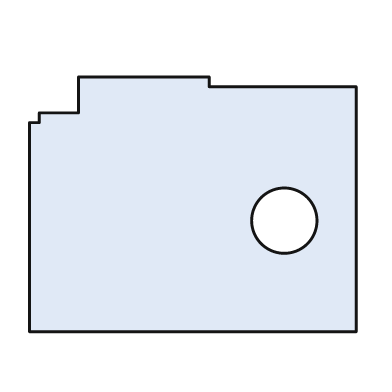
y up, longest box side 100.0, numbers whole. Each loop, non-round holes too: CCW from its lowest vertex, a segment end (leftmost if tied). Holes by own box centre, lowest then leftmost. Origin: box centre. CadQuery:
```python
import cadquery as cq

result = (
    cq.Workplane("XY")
    .moveTo(-50.0, -39.0)
    .lineTo(50.0, -39.0)
    .lineTo(50.0, 36.0)
    .lineTo(5.0, 36.0)
    .lineTo(5.0, 39.0)
    .lineTo(-35.0, 39.0)
    .lineTo(-35.0, 28.0)
    .lineTo(-47.0, 28.0)
    .lineTo(-47.0, 25.0)
    .lineTo(-50.0, 25.0)
    .close()
    .moveTo(28.0, -5.0)
    .circle(10.0)
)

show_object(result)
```